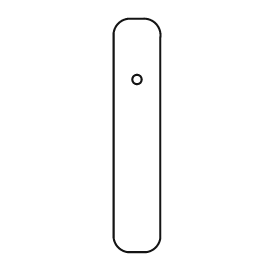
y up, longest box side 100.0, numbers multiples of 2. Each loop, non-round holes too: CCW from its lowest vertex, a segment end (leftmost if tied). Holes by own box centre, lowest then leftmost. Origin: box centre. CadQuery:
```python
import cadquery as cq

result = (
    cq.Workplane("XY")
    .moveTo(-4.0, -50.0)
    .lineTo(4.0, -50.0)
    .threePointArc((8.0, -48.0), (10.0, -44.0))
    .lineTo(10.0, 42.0)
    .threePointArc((8.0, 48.0), (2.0, 50.0))
    .lineTo(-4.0, 50.0)
    .threePointArc((-8.0, 48.0), (-10.0, 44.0))
    .lineTo(-10.0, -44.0)
    .threePointArc((-8.0, -48.0), (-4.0, -50.0))
    .close()
    .moveTo(0.0, 24.0)
    .circle(2.0)
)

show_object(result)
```